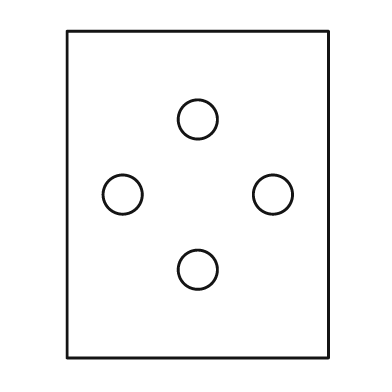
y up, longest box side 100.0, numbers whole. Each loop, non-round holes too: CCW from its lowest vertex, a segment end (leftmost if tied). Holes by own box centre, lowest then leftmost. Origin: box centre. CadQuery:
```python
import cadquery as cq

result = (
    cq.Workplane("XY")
    .moveTo(-40.0, -50.0)
    .lineTo(40.0, -50.0)
    .lineTo(40.0, 50.0)
    .lineTo(-40.0, 50.0)
    .close()
    .moveTo(0.0, -23.0)
    .circle(6.0)
    .moveTo(-23.0, 0.0)
    .circle(6.0)
    .moveTo(23.0, 0.0)
    .circle(6.0)
    .moveTo(0.0, 23.0)
    .circle(6.0)
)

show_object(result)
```